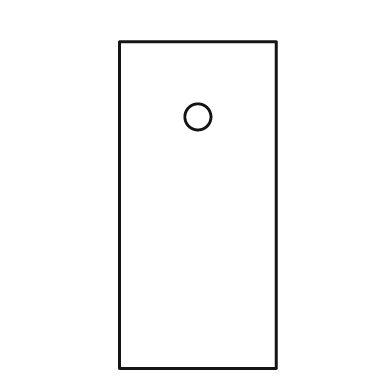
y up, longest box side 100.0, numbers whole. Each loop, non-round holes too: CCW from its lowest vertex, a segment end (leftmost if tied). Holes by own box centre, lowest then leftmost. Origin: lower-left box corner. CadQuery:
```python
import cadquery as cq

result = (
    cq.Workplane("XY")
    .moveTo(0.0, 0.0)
    .lineTo(48.0, 0.0)
    .lineTo(48.0, 100.0)
    .lineTo(0.0, 100.0)
    .close()
    .moveTo(24.0, 77.0)
    .circle(4.0)
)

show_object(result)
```